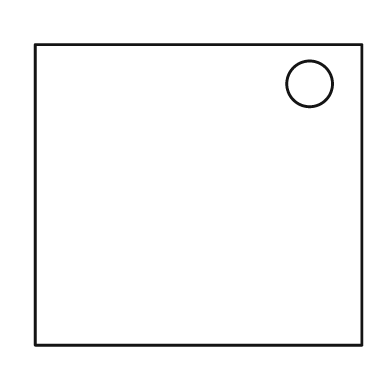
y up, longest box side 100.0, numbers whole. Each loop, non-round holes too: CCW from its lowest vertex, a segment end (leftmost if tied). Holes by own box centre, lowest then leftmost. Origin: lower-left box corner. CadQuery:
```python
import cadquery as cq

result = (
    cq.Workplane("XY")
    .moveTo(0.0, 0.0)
    .lineTo(100.0, 0.0)
    .lineTo(100.0, 92.0)
    .lineTo(0.0, 92.0)
    .close()
    .moveTo(84.0, 80.0)
    .circle(7.0)
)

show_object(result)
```